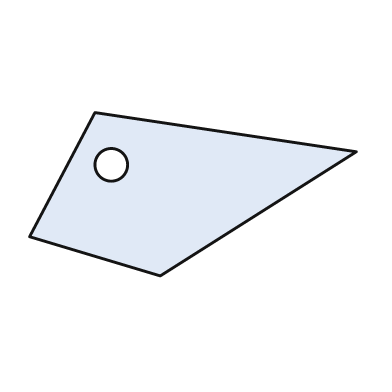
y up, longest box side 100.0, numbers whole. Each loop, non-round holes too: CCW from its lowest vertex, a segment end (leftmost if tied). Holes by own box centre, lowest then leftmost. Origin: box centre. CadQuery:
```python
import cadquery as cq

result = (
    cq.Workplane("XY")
    .moveTo(-10.0, -25.0)
    .lineTo(50.0, 13.0)
    .lineTo(-30.0, 25.0)
    .lineTo(-50.0, -13.0)
    .close()
    .moveTo(-25.0, 9.0)
    .circle(5.0)
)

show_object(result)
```